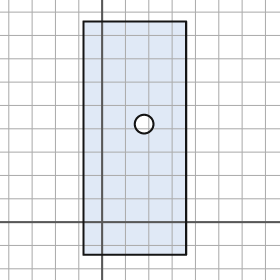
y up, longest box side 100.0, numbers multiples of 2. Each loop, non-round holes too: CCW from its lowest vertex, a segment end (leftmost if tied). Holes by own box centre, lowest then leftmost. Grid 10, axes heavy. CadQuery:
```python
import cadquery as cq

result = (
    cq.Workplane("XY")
    .moveTo(-8.0, -14.0)
    .lineTo(36.0, -14.0)
    .lineTo(36.0, 86.0)
    .lineTo(-8.0, 86.0)
    .close()
    .moveTo(18.0, 42.0)
    .circle(4.0)
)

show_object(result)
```